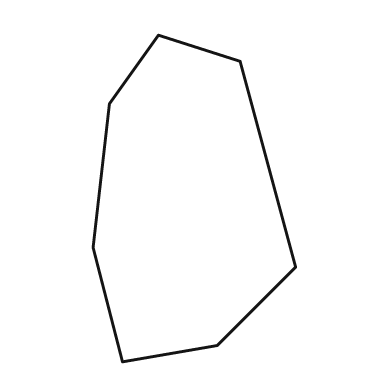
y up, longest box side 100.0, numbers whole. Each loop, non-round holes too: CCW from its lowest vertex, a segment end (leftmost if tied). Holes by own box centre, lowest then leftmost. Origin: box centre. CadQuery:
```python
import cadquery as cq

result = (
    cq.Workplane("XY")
    .moveTo(-22.0, -50.0)
    .lineTo(7.0, -45.0)
    .lineTo(31.0, -21.0)
    .lineTo(14.0, 42.0)
    .lineTo(-11.0, 50.0)
    .lineTo(-26.0, 29.0)
    .lineTo(-31.0, -15.0)
    .close()
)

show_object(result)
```